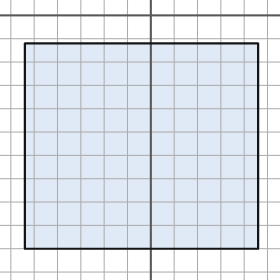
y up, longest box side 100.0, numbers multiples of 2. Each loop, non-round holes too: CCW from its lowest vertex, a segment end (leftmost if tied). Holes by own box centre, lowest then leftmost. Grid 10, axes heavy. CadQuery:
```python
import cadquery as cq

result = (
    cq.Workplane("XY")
    .moveTo(-54.0, -100.0)
    .lineTo(46.0, -100.0)
    .lineTo(46.0, -12.0)
    .lineTo(-54.0, -12.0)
    .close()
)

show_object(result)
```